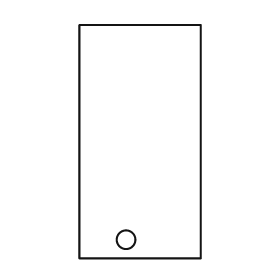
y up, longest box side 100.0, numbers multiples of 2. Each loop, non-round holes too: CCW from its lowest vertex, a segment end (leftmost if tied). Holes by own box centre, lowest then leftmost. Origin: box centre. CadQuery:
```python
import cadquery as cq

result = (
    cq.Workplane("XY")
    .moveTo(-26.0, -50.0)
    .lineTo(26.0, -50.0)
    .lineTo(26.0, 50.0)
    .lineTo(-26.0, 50.0)
    .close()
    .moveTo(-6.0, -42.0)
    .circle(4.0)
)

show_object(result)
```